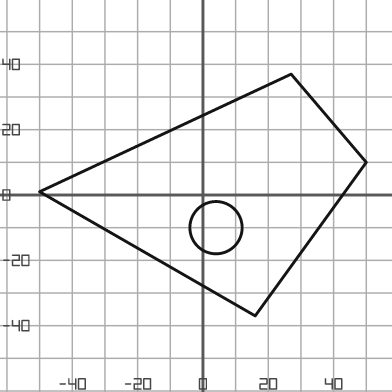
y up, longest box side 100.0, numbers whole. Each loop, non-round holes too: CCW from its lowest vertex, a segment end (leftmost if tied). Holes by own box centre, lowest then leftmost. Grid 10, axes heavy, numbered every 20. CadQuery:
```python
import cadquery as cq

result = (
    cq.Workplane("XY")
    .moveTo(16.0, -37.0)
    .lineTo(50.0, 10.0)
    .lineTo(27.0, 37.0)
    .lineTo(-50.0, 1.0)
    .close()
    .moveTo(4.0, -10.0)
    .circle(8.0)
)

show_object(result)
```